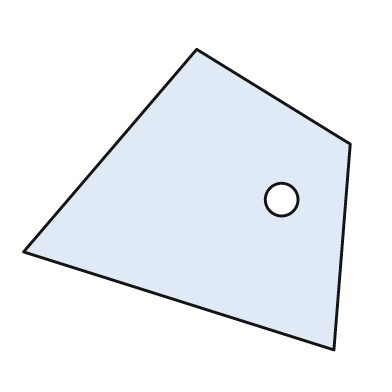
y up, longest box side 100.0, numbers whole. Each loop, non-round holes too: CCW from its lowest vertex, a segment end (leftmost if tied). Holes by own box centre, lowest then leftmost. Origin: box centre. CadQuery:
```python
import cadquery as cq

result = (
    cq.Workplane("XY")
    .moveTo(45.0, -46.0)
    .lineTo(50.0, 17.0)
    .lineTo(3.0, 46.0)
    .lineTo(-50.0, -16.0)
    .close()
    .moveTo(29.0, 0.0)
    .circle(5.0)
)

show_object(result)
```